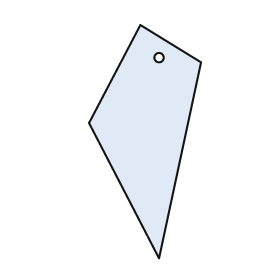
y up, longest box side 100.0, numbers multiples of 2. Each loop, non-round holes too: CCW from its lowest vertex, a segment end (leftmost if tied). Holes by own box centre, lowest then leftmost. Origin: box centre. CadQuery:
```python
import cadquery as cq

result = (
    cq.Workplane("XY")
    .moveTo(6.0, -50.0)
    .lineTo(24.0, 34.0)
    .lineTo(-2.0, 50.0)
    .lineTo(-24.0, 8.0)
    .close()
    .moveTo(6.0, 36.0)
    .circle(2.0)
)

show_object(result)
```